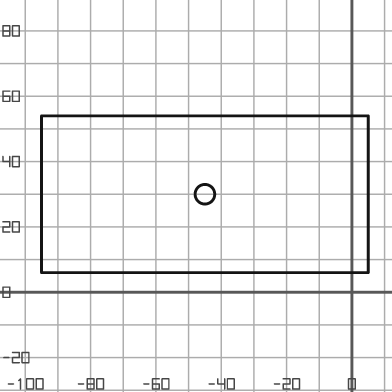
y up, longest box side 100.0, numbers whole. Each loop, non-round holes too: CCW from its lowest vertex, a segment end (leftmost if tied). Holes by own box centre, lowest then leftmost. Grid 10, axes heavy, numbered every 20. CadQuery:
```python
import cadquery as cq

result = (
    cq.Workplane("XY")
    .moveTo(-95.0, 6.0)
    .lineTo(5.0, 6.0)
    .lineTo(5.0, 54.0)
    .lineTo(-95.0, 54.0)
    .close()
    .moveTo(-45.0, 30.0)
    .circle(3.0)
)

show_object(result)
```